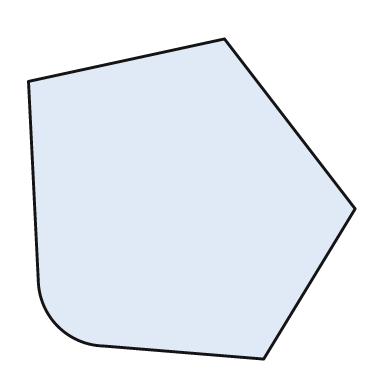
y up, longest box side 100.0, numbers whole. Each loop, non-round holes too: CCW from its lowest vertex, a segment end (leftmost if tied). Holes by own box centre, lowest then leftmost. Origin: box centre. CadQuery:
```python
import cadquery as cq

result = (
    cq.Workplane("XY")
    .moveTo(22.0, -49.0)
    .lineTo(50.0, -3.0)
    .lineTo(10.0, 49.0)
    .lineTo(-50.0, 36.0)
    .lineTo(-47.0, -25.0)
    .threePointArc((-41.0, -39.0), (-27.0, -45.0))
    .close()
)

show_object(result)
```